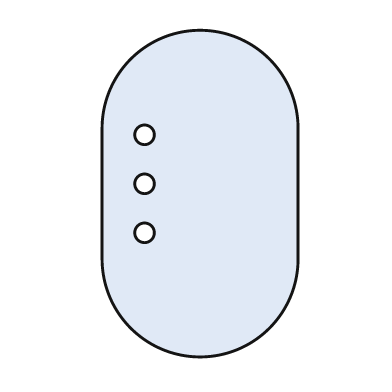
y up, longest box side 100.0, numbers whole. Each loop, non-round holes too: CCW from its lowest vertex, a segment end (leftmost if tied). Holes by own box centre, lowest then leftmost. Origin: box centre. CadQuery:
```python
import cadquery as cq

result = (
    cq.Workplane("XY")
    .moveTo(-30.0, -20.0)
    .threePointArc((0.0, -50.0), (30.0, -20.0))
    .lineTo(30.0, 20.0)
    .threePointArc((0.0, 50.0), (-30.0, 20.0))
    .close()
    .moveTo(-17.0, -12.0)
    .circle(3.0)
    .moveTo(-17.0, 3.0)
    .circle(3.0)
    .moveTo(-17.0, 18.0)
    .circle(3.0)
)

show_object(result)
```